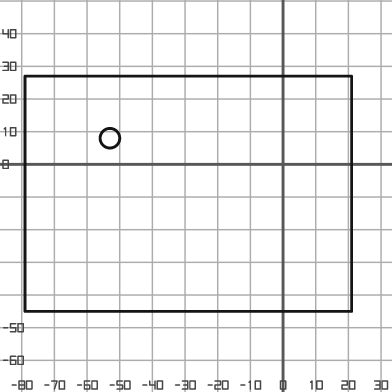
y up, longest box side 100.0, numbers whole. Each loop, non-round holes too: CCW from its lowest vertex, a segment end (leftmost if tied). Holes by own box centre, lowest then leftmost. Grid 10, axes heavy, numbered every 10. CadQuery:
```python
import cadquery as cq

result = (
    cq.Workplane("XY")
    .moveTo(-79.0, -45.0)
    .lineTo(21.0, -45.0)
    .lineTo(21.0, 27.0)
    .lineTo(-79.0, 27.0)
    .close()
    .moveTo(-53.0, 8.0)
    .circle(3.0)
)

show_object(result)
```